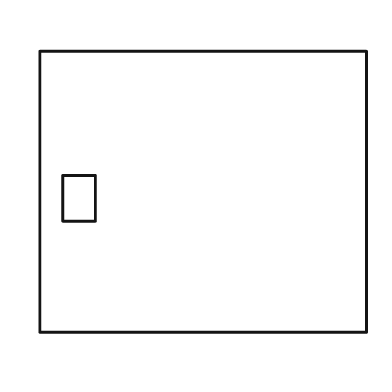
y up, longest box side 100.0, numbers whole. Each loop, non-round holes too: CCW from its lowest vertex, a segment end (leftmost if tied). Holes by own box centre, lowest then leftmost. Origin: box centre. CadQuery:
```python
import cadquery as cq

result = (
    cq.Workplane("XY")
    .moveTo(-50.0, -43.0)
    .lineTo(50.0, -43.0)
    .lineTo(50.0, 43.0)
    .lineTo(-50.0, 43.0)
    .close()
    .moveTo(-43.0, -9.0)
    .lineTo(-33.0, -9.0)
    .lineTo(-33.0, 5.0)
    .lineTo(-43.0, 5.0)
    .close()
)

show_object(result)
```